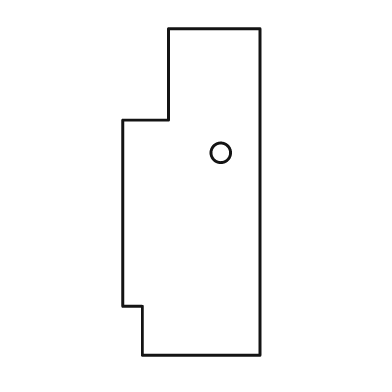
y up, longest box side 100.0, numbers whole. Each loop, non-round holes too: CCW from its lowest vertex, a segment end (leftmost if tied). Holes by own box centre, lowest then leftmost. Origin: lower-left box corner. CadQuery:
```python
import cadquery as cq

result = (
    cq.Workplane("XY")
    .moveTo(6.0, 0.0)
    .lineTo(42.0, 0.0)
    .lineTo(42.0, 100.0)
    .lineTo(14.0, 100.0)
    .lineTo(14.0, 72.0)
    .lineTo(0.0, 72.0)
    .lineTo(0.0, 15.0)
    .lineTo(6.0, 15.0)
    .close()
    .moveTo(30.0, 62.0)
    .circle(3.0)
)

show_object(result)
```